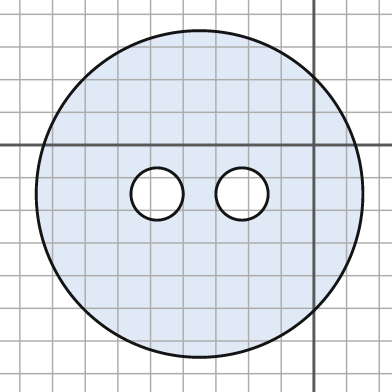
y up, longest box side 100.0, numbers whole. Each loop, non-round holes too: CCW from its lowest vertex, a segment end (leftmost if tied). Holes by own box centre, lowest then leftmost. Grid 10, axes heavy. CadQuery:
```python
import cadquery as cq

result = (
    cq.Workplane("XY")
    .moveTo(-35.0, -15.0)
    .circle(50.0)
    .moveTo(-48.0, -15.0)
    .circle(8.0)
    .moveTo(-22.0, -15.0)
    .circle(8.0)
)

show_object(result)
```